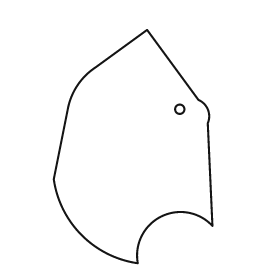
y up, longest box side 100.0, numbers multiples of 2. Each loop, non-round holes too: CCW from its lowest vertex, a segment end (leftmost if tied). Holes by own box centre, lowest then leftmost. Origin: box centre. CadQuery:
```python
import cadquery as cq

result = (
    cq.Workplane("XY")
    .moveTo(2.0, -50.0)
    .threePointArc((12.0, -30.0), (34.0, -34.0))
    .lineTo(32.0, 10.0)
    .threePointArc((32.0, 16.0), (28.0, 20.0))
    .lineTo(6.0, 50.0)
    .lineTo(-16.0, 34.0)
    .threePointArc((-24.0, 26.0), (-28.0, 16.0))
    .lineTo(-34.0, -14.0)
    .threePointArc((-22.0, -38.0), (2.0, -50.0))
    .close()
    .moveTo(20.0, 16.0)
    .circle(2.0)
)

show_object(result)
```